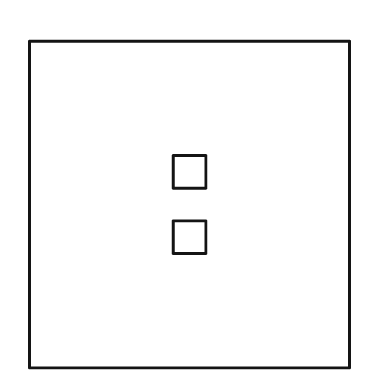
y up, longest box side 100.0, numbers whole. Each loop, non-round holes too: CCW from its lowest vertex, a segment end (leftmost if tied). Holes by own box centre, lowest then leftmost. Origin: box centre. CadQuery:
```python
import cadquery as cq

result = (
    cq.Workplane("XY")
    .moveTo(-49.0, -50.0)
    .lineTo(49.0, -50.0)
    .lineTo(49.0, 50.0)
    .lineTo(-49.0, 50.0)
    .close()
    .moveTo(-5.0, -15.0)
    .lineTo(5.0, -15.0)
    .lineTo(5.0, -5.0)
    .lineTo(-5.0, -5.0)
    .close()
    .moveTo(-5.0, 5.0)
    .lineTo(5.0, 5.0)
    .lineTo(5.0, 15.0)
    .lineTo(-5.0, 15.0)
    .close()
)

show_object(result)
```